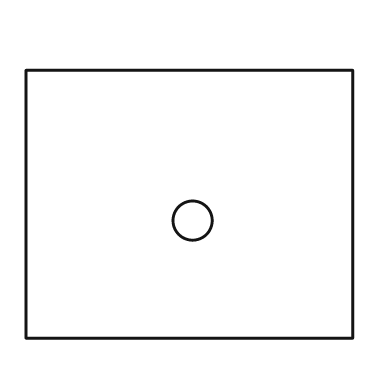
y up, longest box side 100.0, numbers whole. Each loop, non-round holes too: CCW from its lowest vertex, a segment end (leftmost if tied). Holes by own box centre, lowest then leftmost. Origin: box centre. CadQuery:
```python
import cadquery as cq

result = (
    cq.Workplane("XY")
    .moveTo(-50.0, -41.0)
    .lineTo(50.0, -41.0)
    .lineTo(50.0, 41.0)
    .lineTo(-50.0, 41.0)
    .close()
    .moveTo(1.0, -5.0)
    .circle(6.0)
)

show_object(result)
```